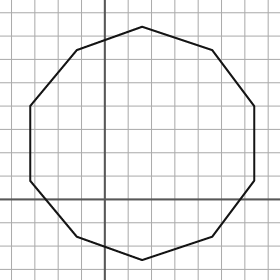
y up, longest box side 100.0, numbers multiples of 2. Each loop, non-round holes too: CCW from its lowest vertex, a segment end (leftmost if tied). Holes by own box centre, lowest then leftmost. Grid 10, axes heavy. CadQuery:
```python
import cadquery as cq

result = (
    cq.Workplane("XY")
    .moveTo(16.0, -26.0)
    .lineTo(46.0, -16.0)
    .lineTo(64.0, 8.0)
    .lineTo(64.0, 40.0)
    .lineTo(46.0, 64.0)
    .lineTo(16.0, 74.0)
    .lineTo(-12.0, 64.0)
    .lineTo(-32.0, 40.0)
    .lineTo(-32.0, 8.0)
    .lineTo(-12.0, -16.0)
    .close()
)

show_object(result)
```